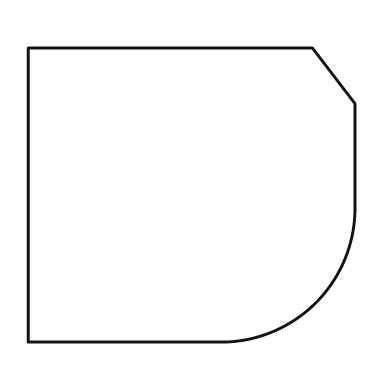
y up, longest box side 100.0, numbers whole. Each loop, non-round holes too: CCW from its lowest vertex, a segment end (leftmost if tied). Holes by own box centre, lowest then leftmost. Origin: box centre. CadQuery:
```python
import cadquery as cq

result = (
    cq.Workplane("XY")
    .moveTo(-50.0, -45.0)
    .lineTo(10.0, -45.0)
    .threePointArc((38.0, -33.0), (50.0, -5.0))
    .lineTo(50.0, 28.0)
    .lineTo(37.0, 45.0)
    .lineTo(-50.0, 45.0)
    .close()
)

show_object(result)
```